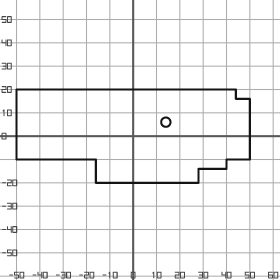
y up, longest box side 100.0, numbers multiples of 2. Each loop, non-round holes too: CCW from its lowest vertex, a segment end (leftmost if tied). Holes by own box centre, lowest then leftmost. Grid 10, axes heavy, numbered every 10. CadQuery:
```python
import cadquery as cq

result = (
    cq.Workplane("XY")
    .moveTo(-16.0, -20.0)
    .lineTo(28.0, -20.0)
    .lineTo(28.0, -14.0)
    .lineTo(40.0, -14.0)
    .lineTo(40.0, -10.0)
    .lineTo(50.0, -10.0)
    .lineTo(50.0, 16.0)
    .lineTo(44.0, 16.0)
    .lineTo(44.0, 20.0)
    .lineTo(-50.0, 20.0)
    .lineTo(-50.0, -10.0)
    .lineTo(-16.0, -10.0)
    .close()
    .moveTo(14.0, 6.0)
    .circle(2.0)
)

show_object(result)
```